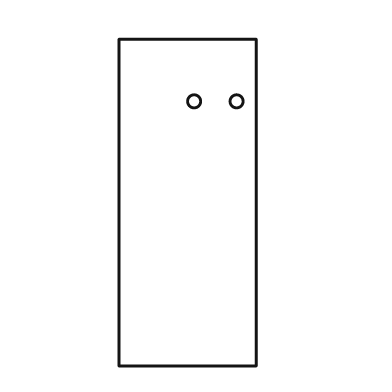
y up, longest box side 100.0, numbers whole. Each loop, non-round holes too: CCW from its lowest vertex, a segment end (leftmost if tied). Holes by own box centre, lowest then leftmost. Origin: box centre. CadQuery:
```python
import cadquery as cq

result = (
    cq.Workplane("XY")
    .moveTo(-21.0, -50.0)
    .lineTo(21.0, -50.0)
    .lineTo(21.0, 50.0)
    .lineTo(-21.0, 50.0)
    .close()
    .moveTo(2.0, 31.0)
    .circle(2.0)
    .moveTo(15.0, 31.0)
    .circle(2.0)
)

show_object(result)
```